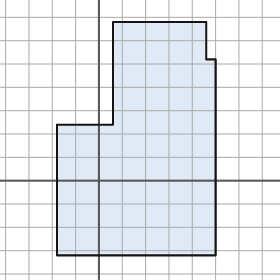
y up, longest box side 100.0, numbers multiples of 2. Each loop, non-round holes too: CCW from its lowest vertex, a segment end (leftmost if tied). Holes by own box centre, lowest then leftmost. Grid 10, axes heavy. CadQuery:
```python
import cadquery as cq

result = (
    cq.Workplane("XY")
    .moveTo(-18.0, -32.0)
    .lineTo(50.0, -32.0)
    .lineTo(50.0, 52.0)
    .lineTo(46.0, 52.0)
    .lineTo(46.0, 68.0)
    .lineTo(6.0, 68.0)
    .lineTo(6.0, 24.0)
    .lineTo(-18.0, 24.0)
    .close()
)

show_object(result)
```